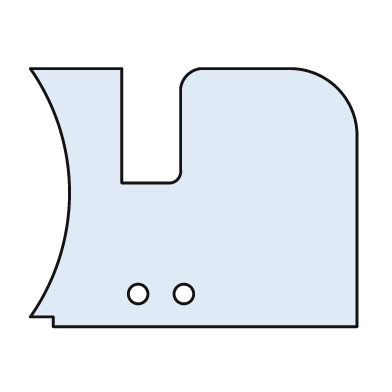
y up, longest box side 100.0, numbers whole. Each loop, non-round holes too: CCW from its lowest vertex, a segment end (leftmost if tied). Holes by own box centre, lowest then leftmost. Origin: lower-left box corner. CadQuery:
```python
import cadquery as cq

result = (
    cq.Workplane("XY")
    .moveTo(7.0, 0.0)
    .lineTo(100.0, 0.0)
    .lineTo(100.0, 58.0)
    .threePointArc((94.0, 73.0), (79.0, 79.0))
    .lineTo(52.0, 79.0)
    .threePointArc((48.0, 77.0), (46.0, 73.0))
    .lineTo(46.0, 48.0)
    .threePointArc((45.0, 45.0), (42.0, 44.0))
    .lineTo(28.0, 44.0)
    .lineTo(28.0, 79.0)
    .lineTo(0.0, 79.0)
    .threePointArc((12.0, 41.0), (0.0, 3.0))
    .lineTo(7.0, 3.0)
    .close()
    .moveTo(33.0, 10.0)
    .circle(3.0)
    .moveTo(47.0, 10.0)
    .circle(3.0)
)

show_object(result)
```